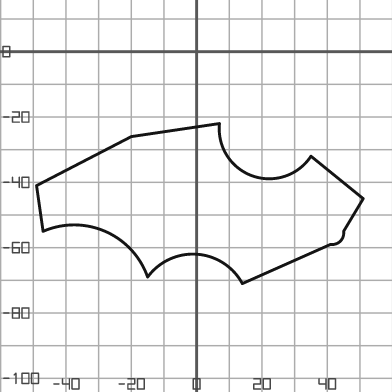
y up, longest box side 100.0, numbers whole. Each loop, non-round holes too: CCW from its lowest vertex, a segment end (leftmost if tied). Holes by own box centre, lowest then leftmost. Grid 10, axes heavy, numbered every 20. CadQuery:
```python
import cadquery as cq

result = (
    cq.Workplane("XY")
    .moveTo(14.0, -71.0)
    .lineTo(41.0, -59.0)
    .threePointArc((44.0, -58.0), (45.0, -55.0))
    .lineTo(51.0, -45.0)
    .lineTo(35.0, -32.0)
    .threePointArc((17.0, -38.0), (7.0, -22.0))
    .lineTo(-20.0, -26.0)
    .lineTo(-49.0, -41.0)
    .lineTo(-47.0, -55.0)
    .threePointArc((-28.0, -55.0), (-15.0, -69.0))
    .threePointArc((0.0, -62.0), (14.0, -71.0))
    .close()
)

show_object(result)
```